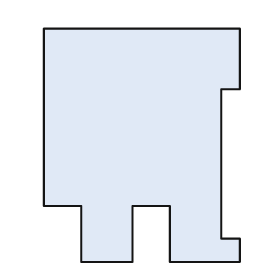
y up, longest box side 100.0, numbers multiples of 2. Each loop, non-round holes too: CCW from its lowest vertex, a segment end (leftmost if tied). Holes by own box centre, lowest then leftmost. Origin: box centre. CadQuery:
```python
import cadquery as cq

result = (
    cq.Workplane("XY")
    .moveTo(-26.0, -50.0)
    .lineTo(-4.0, -50.0)
    .lineTo(-4.0, -26.0)
    .lineTo(12.0, -26.0)
    .lineTo(12.0, -50.0)
    .lineTo(42.0, -50.0)
    .lineTo(42.0, -40.0)
    .lineTo(34.0, -40.0)
    .lineTo(34.0, 24.0)
    .lineTo(42.0, 24.0)
    .lineTo(42.0, 50.0)
    .lineTo(-42.0, 50.0)
    .lineTo(-42.0, -26.0)
    .lineTo(-26.0, -26.0)
    .close()
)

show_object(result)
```